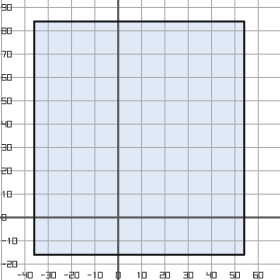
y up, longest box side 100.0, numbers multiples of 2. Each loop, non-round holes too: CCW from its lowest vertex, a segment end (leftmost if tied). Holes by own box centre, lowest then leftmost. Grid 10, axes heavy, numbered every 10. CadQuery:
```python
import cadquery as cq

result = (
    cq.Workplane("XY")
    .moveTo(-36.0, -16.0)
    .lineTo(54.0, -16.0)
    .lineTo(54.0, 84.0)
    .lineTo(-36.0, 84.0)
    .close()
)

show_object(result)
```